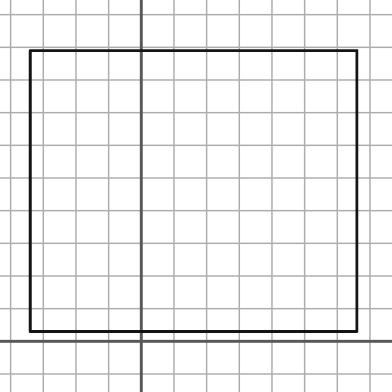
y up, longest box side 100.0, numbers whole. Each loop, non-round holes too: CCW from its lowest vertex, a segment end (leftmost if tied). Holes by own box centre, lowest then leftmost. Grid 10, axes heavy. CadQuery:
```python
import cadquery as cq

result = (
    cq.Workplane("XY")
    .moveTo(-34.0, 3.0)
    .lineTo(66.0, 3.0)
    .lineTo(66.0, 89.0)
    .lineTo(-34.0, 89.0)
    .close()
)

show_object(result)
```